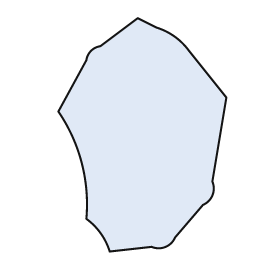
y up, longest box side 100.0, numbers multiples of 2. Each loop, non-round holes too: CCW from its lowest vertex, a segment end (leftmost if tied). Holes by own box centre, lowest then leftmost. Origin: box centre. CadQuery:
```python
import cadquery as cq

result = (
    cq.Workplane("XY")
    .moveTo(-14.0, -50.0)
    .lineTo(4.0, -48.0)
    .threePointArc((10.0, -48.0), (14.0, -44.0))
    .lineTo(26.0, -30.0)
    .threePointArc((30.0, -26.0), (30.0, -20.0))
    .lineTo(36.0, 16.0)
    .lineTo(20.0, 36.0)
    .threePointArc((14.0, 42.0), (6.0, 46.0))
    .lineTo(-2.0, 50.0)
    .lineTo(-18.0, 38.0)
    .threePointArc((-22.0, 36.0), (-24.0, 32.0))
    .lineTo(-36.0, 10.0)
    .threePointArc((-26.0, -12.0), (-24.0, -36.0))
    .threePointArc((-18.0, -42.0), (-14.0, -50.0))
    .close()
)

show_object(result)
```